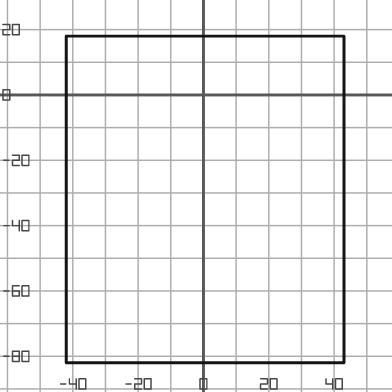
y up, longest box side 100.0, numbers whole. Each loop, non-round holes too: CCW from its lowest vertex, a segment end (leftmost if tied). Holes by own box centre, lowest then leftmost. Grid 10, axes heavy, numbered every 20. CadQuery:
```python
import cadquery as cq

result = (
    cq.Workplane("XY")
    .moveTo(-42.0, -82.0)
    .lineTo(43.0, -82.0)
    .lineTo(43.0, 18.0)
    .lineTo(-42.0, 18.0)
    .close()
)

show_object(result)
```